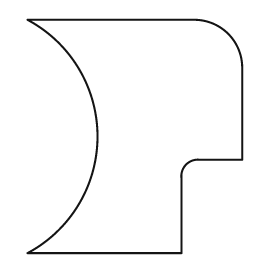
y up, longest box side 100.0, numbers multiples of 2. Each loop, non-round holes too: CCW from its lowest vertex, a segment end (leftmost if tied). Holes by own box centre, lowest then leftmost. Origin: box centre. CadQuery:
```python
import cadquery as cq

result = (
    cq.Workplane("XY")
    .moveTo(-46.0, -50.0)
    .lineTo(20.0, -50.0)
    .lineTo(20.0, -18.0)
    .threePointArc((22.0, -12.0), (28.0, -10.0))
    .lineTo(46.0, -10.0)
    .lineTo(46.0, 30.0)
    .threePointArc((40.0, 44.0), (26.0, 50.0))
    .lineTo(-46.0, 50.0)
    .threePointArc((-16.0, 0.0), (-46.0, -50.0))
    .close()
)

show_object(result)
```